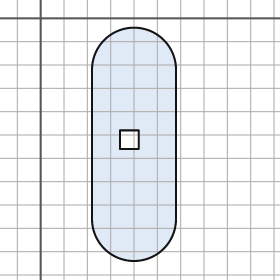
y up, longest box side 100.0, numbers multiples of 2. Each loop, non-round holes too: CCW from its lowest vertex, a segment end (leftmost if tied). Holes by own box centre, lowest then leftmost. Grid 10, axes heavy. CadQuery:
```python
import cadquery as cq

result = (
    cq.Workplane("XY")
    .moveTo(22.0, -86.0)
    .threePointArc((40.0, -104.0), (58.0, -86.0))
    .lineTo(58.0, -22.0)
    .threePointArc((40.0, -4.0), (22.0, -22.0))
    .close()
    .moveTo(34.0, -56.0)
    .lineTo(42.0, -56.0)
    .lineTo(42.0, -48.0)
    .lineTo(34.0, -48.0)
    .close()
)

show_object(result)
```